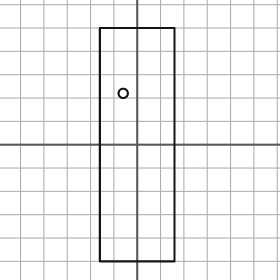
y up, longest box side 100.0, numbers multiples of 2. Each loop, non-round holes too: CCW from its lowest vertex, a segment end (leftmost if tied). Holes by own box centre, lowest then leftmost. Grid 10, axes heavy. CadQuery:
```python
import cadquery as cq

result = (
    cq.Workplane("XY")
    .moveTo(-16.0, -50.0)
    .lineTo(16.0, -50.0)
    .lineTo(16.0, 50.0)
    .lineTo(-16.0, 50.0)
    .close()
    .moveTo(-6.0, 22.0)
    .circle(2.0)
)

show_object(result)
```